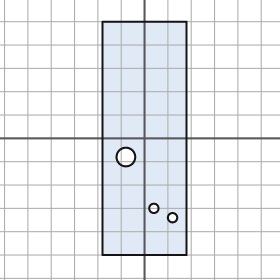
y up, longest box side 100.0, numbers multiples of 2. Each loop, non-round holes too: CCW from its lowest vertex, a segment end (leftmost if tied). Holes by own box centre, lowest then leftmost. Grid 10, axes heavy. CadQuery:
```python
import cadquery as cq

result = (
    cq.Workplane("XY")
    .moveTo(-18.0, -50.0)
    .lineTo(18.0, -50.0)
    .lineTo(18.0, 50.0)
    .lineTo(-18.0, 50.0)
    .close()
    .moveTo(12.0, -34.0)
    .circle(2.0)
    .moveTo(4.0, -30.0)
    .circle(2.0)
    .moveTo(-8.0, -8.0)
    .circle(4.0)
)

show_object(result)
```